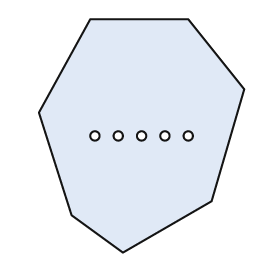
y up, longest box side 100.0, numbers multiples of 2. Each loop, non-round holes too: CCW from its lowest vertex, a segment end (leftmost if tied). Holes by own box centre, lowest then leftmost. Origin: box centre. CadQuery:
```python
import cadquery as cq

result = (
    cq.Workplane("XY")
    .moveTo(-8.0, -50.0)
    .lineTo(30.0, -28.0)
    .lineTo(44.0, 20.0)
    .lineTo(20.0, 50.0)
    .lineTo(-22.0, 50.0)
    .lineTo(-44.0, 10.0)
    .lineTo(-30.0, -34.0)
    .close()
    .moveTo(-20.0, 0.0)
    .circle(2.0)
    .moveTo(-10.0, 0.0)
    .circle(2.0)
    .moveTo(0.0, 0.0)
    .circle(2.0)
    .moveTo(10.0, 0.0)
    .circle(2.0)
    .moveTo(20.0, 0.0)
    .circle(2.0)
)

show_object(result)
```